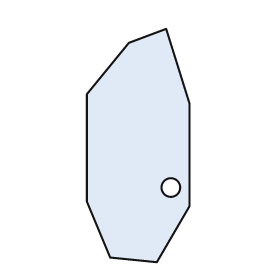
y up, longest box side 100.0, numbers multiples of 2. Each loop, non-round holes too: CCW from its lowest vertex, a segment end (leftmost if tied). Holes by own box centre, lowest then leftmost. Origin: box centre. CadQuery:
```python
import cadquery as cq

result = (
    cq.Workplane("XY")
    .moveTo(8.0, -50.0)
    .lineTo(22.0, -26.0)
    .lineTo(22.0, 18.0)
    .lineTo(12.0, 50.0)
    .lineTo(-4.0, 44.0)
    .lineTo(-22.0, 22.0)
    .lineTo(-22.0, -24.0)
    .lineTo(-12.0, -48.0)
    .close()
    .moveTo(14.0, -18.0)
    .circle(4.0)
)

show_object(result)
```